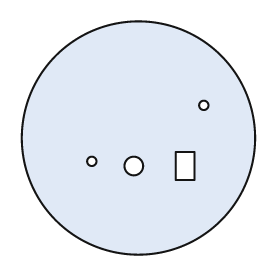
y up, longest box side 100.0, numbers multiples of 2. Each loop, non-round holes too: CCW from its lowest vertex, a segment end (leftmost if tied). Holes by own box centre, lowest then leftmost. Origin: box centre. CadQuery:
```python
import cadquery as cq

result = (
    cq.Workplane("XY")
    .moveTo(0.0, 0.0)
    .circle(50.0)
    .moveTo(-2.0, -12.0)
    .circle(4.0)
    .moveTo(16.0, -18.0)
    .lineTo(24.0, -18.0)
    .lineTo(24.0, -6.0)
    .lineTo(16.0, -6.0)
    .close()
    .moveTo(-20.0, -10.0)
    .circle(2.0)
    .moveTo(28.0, 14.0)
    .circle(2.0)
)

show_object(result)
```